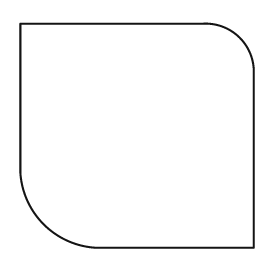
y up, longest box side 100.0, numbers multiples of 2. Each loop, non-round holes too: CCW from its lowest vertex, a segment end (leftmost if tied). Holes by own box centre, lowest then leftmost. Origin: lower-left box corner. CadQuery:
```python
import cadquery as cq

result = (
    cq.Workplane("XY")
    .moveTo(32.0, 0.0)
    .lineTo(100.0, 0.0)
    .lineTo(100.0, 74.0)
    .threePointArc((94.0, 90.0), (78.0, 96.0))
    .lineTo(0.0, 96.0)
    .lineTo(0.0, 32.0)
    .threePointArc((10.0, 10.0), (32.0, 0.0))
    .close()
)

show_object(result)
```